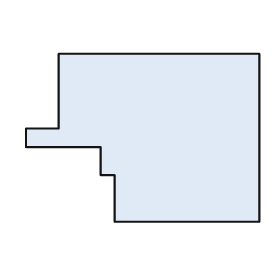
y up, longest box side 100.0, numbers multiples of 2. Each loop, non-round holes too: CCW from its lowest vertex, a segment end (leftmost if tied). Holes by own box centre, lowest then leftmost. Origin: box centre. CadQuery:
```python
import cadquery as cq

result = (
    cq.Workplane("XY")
    .moveTo(-12.0, -36.0)
    .lineTo(50.0, -36.0)
    .lineTo(50.0, 36.0)
    .lineTo(-36.0, 36.0)
    .lineTo(-36.0, 4.0)
    .lineTo(-50.0, 4.0)
    .lineTo(-50.0, -4.0)
    .lineTo(-18.0, -4.0)
    .lineTo(-18.0, -16.0)
    .lineTo(-12.0, -16.0)
    .close()
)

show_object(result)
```